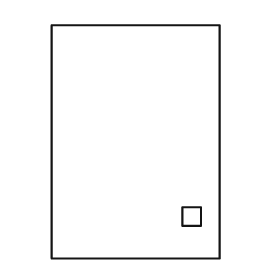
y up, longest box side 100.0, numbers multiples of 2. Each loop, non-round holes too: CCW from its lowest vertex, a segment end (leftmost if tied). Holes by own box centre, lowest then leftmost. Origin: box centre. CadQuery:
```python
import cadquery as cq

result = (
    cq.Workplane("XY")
    .moveTo(-36.0, -50.0)
    .lineTo(36.0, -50.0)
    .lineTo(36.0, 50.0)
    .lineTo(-36.0, 50.0)
    .close()
    .moveTo(20.0, -36.0)
    .lineTo(28.0, -36.0)
    .lineTo(28.0, -28.0)
    .lineTo(20.0, -28.0)
    .close()
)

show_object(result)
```